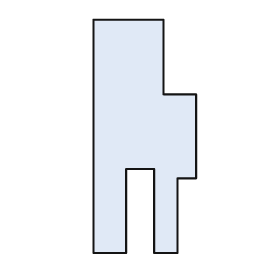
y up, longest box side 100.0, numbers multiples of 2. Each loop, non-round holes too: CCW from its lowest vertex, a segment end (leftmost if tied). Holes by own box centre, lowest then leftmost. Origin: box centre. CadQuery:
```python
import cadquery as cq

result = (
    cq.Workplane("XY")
    .moveTo(-22.0, -50.0)
    .lineTo(-8.0, -50.0)
    .lineTo(-8.0, -14.0)
    .lineTo(4.0, -14.0)
    .lineTo(4.0, -50.0)
    .lineTo(14.0, -50.0)
    .lineTo(14.0, -18.0)
    .lineTo(22.0, -18.0)
    .lineTo(22.0, 18.0)
    .lineTo(8.0, 18.0)
    .lineTo(8.0, 50.0)
    .lineTo(-22.0, 50.0)
    .close()
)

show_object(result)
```